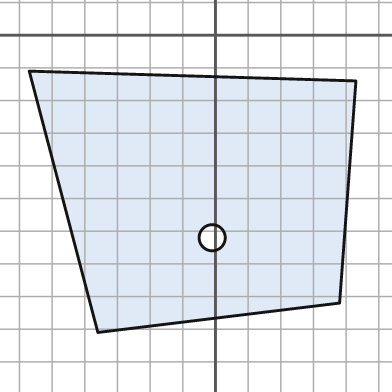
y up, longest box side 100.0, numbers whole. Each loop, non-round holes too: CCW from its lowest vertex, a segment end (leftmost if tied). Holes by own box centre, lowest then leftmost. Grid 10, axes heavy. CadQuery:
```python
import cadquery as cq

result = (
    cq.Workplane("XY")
    .moveTo(-36.0, -91.0)
    .lineTo(38.0, -82.0)
    .lineTo(43.0, -14.0)
    .lineTo(-57.0, -11.0)
    .close()
    .moveTo(-1.0, -62.0)
    .circle(4.0)
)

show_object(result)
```